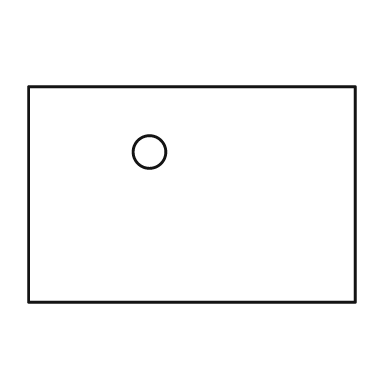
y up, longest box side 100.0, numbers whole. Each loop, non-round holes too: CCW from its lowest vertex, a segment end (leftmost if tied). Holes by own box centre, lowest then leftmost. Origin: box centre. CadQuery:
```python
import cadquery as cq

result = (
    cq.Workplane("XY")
    .moveTo(-50.0, -33.0)
    .lineTo(50.0, -33.0)
    .lineTo(50.0, 33.0)
    .lineTo(-50.0, 33.0)
    .close()
    .moveTo(-13.0, 13.0)
    .circle(5.0)
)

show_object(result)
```